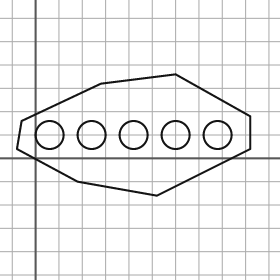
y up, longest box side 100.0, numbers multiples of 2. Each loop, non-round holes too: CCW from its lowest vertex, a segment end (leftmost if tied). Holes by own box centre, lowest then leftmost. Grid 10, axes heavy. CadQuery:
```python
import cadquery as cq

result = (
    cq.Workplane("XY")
    .moveTo(52.0, -16.0)
    .lineTo(92.0, 4.0)
    .lineTo(92.0, 18.0)
    .lineTo(60.0, 36.0)
    .lineTo(28.0, 32.0)
    .lineTo(-6.0, 16.0)
    .lineTo(-8.0, 4.0)
    .lineTo(18.0, -10.0)
    .close()
    .moveTo(6.0, 10.0)
    .circle(6.0)
    .moveTo(24.0, 10.0)
    .circle(6.0)
    .moveTo(42.0, 10.0)
    .circle(6.0)
    .moveTo(60.0, 10.0)
    .circle(6.0)
    .moveTo(78.0, 10.0)
    .circle(6.0)
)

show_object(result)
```